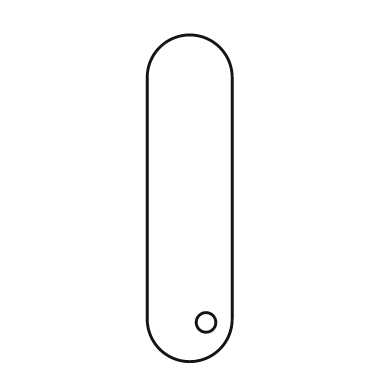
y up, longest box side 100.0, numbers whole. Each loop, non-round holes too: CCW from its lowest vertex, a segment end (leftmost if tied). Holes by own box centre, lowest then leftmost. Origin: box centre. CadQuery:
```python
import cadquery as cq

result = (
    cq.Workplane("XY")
    .moveTo(-13.0, -37.0)
    .threePointArc((0.0, -50.0), (13.0, -37.0))
    .lineTo(13.0, 37.0)
    .threePointArc((0.0, 50.0), (-13.0, 37.0))
    .close()
    .moveTo(5.0, -38.0)
    .circle(3.0)
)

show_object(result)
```